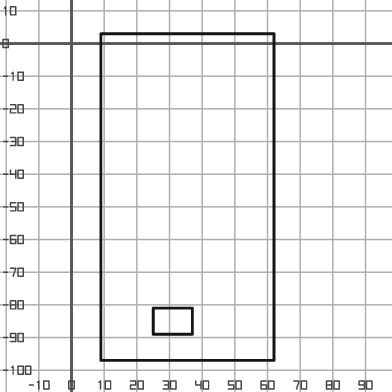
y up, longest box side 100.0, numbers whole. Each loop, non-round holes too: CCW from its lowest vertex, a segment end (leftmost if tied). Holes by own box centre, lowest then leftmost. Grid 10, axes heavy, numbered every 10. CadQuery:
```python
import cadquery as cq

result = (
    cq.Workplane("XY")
    .moveTo(9.0, -97.0)
    .lineTo(62.0, -97.0)
    .lineTo(62.0, 3.0)
    .lineTo(9.0, 3.0)
    .close()
    .moveTo(25.0, -89.0)
    .lineTo(37.0, -89.0)
    .lineTo(37.0, -81.0)
    .lineTo(25.0, -81.0)
    .close()
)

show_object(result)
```